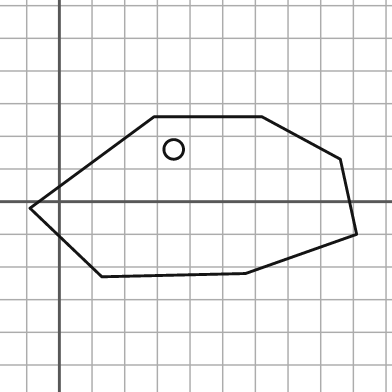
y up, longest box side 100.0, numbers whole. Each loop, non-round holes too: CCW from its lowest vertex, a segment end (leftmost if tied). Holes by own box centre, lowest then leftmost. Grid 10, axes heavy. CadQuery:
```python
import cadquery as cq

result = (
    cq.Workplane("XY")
    .moveTo(13.0, -23.0)
    .lineTo(57.0, -22.0)
    .lineTo(91.0, -10.0)
    .lineTo(86.0, 13.0)
    .lineTo(62.0, 26.0)
    .lineTo(29.0, 26.0)
    .lineTo(-9.0, -2.0)
    .close()
    .moveTo(35.0, 16.0)
    .circle(3.0)
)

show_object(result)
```